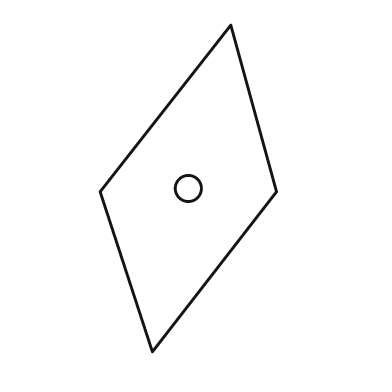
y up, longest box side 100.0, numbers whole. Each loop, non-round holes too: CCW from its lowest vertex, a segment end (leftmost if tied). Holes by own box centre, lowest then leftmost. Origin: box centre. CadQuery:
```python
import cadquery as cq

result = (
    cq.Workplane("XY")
    .moveTo(-11.0, -50.0)
    .lineTo(27.0, -1.0)
    .lineTo(13.0, 50.0)
    .lineTo(-27.0, -1.0)
    .close()
    .moveTo(0.0, 0.0)
    .circle(4.0)
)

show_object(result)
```